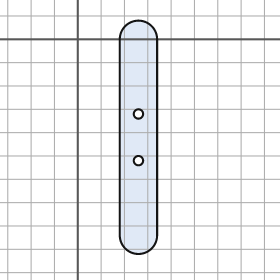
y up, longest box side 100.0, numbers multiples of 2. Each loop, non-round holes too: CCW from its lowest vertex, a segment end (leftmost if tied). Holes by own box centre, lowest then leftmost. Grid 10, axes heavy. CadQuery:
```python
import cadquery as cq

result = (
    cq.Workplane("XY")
    .moveTo(18.0, -84.0)
    .threePointArc((26.0, -92.0), (34.0, -84.0))
    .lineTo(34.0, 0.0)
    .threePointArc((26.0, 8.0), (18.0, 0.0))
    .close()
    .moveTo(26.0, -52.0)
    .circle(2.0)
    .moveTo(26.0, -32.0)
    .circle(2.0)
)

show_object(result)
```